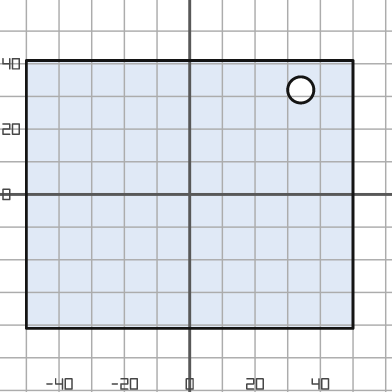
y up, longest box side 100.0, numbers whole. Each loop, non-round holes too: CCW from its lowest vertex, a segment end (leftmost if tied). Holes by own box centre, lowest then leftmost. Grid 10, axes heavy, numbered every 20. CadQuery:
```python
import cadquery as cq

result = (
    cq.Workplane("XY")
    .moveTo(-50.0, -41.0)
    .lineTo(50.0, -41.0)
    .lineTo(50.0, 41.0)
    .lineTo(-50.0, 41.0)
    .close()
    .moveTo(34.0, 32.0)
    .circle(4.0)
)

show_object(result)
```